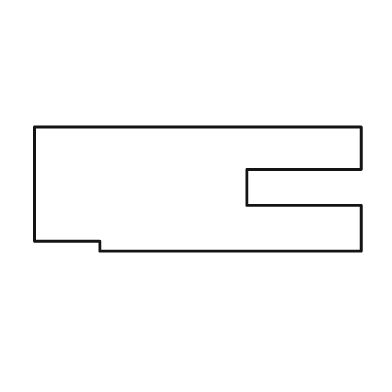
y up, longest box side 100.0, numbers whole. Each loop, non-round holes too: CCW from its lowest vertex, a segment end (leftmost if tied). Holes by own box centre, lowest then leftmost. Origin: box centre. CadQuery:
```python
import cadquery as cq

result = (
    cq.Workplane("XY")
    .moveTo(-30.0, -19.0)
    .lineTo(50.0, -19.0)
    .lineTo(50.0, -5.0)
    .lineTo(15.0, -5.0)
    .lineTo(15.0, 6.0)
    .lineTo(50.0, 6.0)
    .lineTo(50.0, 19.0)
    .lineTo(-50.0, 19.0)
    .lineTo(-50.0, -16.0)
    .lineTo(-30.0, -16.0)
    .close()
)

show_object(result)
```